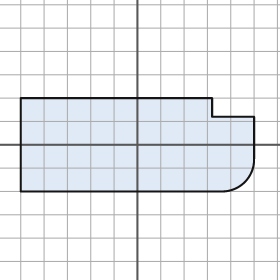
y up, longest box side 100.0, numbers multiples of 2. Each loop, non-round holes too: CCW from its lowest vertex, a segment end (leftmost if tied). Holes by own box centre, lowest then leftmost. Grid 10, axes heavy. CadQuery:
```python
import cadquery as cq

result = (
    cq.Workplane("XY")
    .moveTo(-50.0, -20.0)
    .lineTo(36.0, -20.0)
    .threePointArc((46.0, -16.0), (50.0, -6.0))
    .lineTo(50.0, 12.0)
    .lineTo(32.0, 12.0)
    .lineTo(32.0, 20.0)
    .lineTo(-50.0, 20.0)
    .close()
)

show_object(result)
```